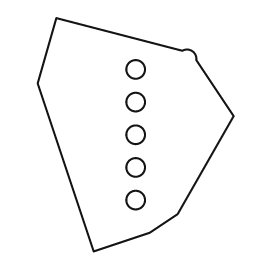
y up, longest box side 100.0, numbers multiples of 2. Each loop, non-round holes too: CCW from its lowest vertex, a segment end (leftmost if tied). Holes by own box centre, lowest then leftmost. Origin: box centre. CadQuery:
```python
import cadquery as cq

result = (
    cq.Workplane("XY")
    .moveTo(-18.0, -50.0)
    .lineTo(6.0, -42.0)
    .lineTo(18.0, -34.0)
    .lineTo(42.0, 8.0)
    .lineTo(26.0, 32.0)
    .threePointArc((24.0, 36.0), (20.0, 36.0))
    .lineTo(-34.0, 50.0)
    .lineTo(-42.0, 22.0)
    .close()
    .moveTo(0.0, -28.0)
    .circle(4.0)
    .moveTo(0.0, -14.0)
    .circle(4.0)
    .moveTo(0.0, 0.0)
    .circle(4.0)
    .moveTo(0.0, 14.0)
    .circle(4.0)
    .moveTo(0.0, 28.0)
    .circle(4.0)
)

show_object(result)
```